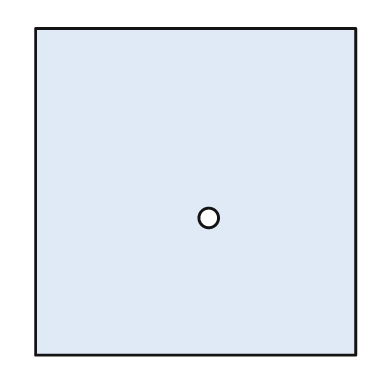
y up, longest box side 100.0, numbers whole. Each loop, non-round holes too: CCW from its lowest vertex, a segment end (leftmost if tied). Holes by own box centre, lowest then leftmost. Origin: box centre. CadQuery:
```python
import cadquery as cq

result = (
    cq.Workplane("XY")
    .moveTo(-49.0, -50.0)
    .lineTo(49.0, -50.0)
    .lineTo(49.0, 50.0)
    .lineTo(-49.0, 50.0)
    .close()
    .moveTo(4.0, -8.0)
    .circle(3.0)
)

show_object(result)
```